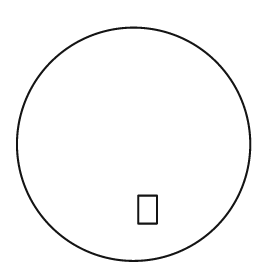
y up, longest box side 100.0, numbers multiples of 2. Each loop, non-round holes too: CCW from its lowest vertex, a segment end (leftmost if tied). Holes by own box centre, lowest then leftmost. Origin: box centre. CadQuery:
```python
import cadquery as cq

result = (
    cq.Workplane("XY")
    .moveTo(0.0, 0.0)
    .circle(50.0)
    .moveTo(2.0, -34.0)
    .lineTo(10.0, -34.0)
    .lineTo(10.0, -22.0)
    .lineTo(2.0, -22.0)
    .close()
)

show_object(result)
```